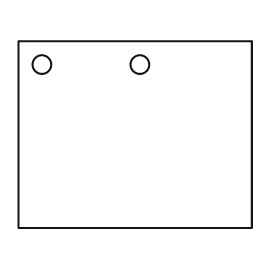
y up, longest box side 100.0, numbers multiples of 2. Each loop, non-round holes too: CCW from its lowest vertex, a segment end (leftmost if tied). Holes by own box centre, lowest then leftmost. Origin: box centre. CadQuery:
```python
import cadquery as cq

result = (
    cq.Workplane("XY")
    .moveTo(-50.0, -40.0)
    .lineTo(50.0, -40.0)
    .lineTo(50.0, 40.0)
    .lineTo(-50.0, 40.0)
    .close()
    .moveTo(-40.0, 30.0)
    .circle(4.0)
    .moveTo(2.0, 30.0)
    .circle(4.0)
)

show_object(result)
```